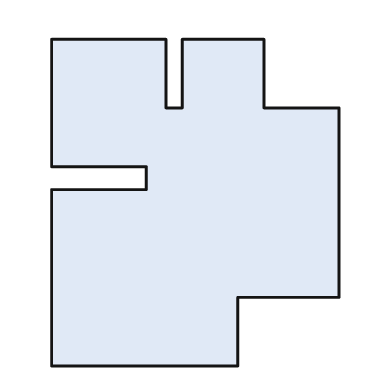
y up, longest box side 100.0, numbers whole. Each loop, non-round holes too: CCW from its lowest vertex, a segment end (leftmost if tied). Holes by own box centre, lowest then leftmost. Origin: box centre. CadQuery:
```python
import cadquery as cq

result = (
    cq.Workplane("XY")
    .moveTo(-44.0, -50.0)
    .lineTo(13.0, -50.0)
    .lineTo(13.0, -29.0)
    .lineTo(44.0, -29.0)
    .lineTo(44.0, 29.0)
    .lineTo(21.0, 29.0)
    .lineTo(21.0, 50.0)
    .lineTo(-4.0, 50.0)
    .lineTo(-4.0, 29.0)
    .lineTo(-9.0, 29.0)
    .lineTo(-9.0, 50.0)
    .lineTo(-44.0, 50.0)
    .lineTo(-44.0, 11.0)
    .lineTo(-15.0, 11.0)
    .lineTo(-15.0, 4.0)
    .lineTo(-44.0, 4.0)
    .close()
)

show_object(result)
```